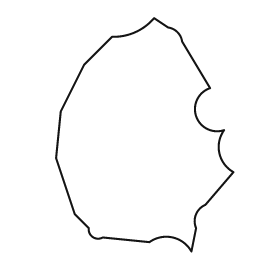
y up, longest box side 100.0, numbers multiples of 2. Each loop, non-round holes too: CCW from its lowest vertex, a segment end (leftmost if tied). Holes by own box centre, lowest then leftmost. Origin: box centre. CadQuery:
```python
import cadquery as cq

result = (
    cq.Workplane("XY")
    .moveTo(20.0, -50.0)
    .lineTo(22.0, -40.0)
    .threePointArc((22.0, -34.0), (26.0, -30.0))
    .lineTo(38.0, -16.0)
    .threePointArc((32.0, -8.0), (34.0, 2.0))
    .threePointArc((22.0, 8.0), (28.0, 20.0))
    .lineTo(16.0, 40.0)
    .threePointArc((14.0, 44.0), (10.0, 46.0))
    .lineTo(4.0, 50.0)
    .threePointArc((-4.0, 44.0), (-14.0, 42.0))
    .lineTo(-26.0, 30.0)
    .lineTo(-36.0, 10.0)
    .lineTo(-38.0, -10.0)
    .lineTo(-30.0, -34.0)
    .lineTo(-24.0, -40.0)
    .threePointArc((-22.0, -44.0), (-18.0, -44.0))
    .lineTo(2.0, -46.0)
    .threePointArc((12.0, -44.0), (20.0, -50.0))
    .close()
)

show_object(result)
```